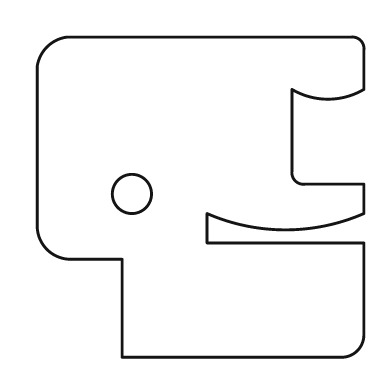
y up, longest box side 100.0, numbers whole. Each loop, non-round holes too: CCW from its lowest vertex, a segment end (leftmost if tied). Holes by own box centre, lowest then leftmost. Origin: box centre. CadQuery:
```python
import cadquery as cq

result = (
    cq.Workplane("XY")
    .moveTo(-24.0, -49.0)
    .lineTo(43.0, -49.0)
    .threePointArc((48.0, -47.0), (50.0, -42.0))
    .lineTo(50.0, -14.0)
    .lineTo(2.0, -14.0)
    .lineTo(2.0, -5.0)
    .threePointArc((26.0, -10.0), (50.0, -5.0))
    .lineTo(50.0, 4.0)
    .lineTo(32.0, 4.0)
    .threePointArc((29.0, 5.0), (28.0, 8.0))
    .lineTo(28.0, 33.0)
    .threePointArc((39.0, 30.0), (50.0, 33.0))
    .lineTo(50.0, 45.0)
    .threePointArc((49.0, 48.0), (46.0, 49.0))
    .lineTo(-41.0, 49.0)
    .threePointArc((-47.0, 46.0), (-50.0, 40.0))
    .lineTo(-50.0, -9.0)
    .threePointArc((-47.0, -16.0), (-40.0, -19.0))
    .lineTo(-24.0, -19.0)
    .close()
    .moveTo(-21.0, 1.0)
    .circle(6.0)
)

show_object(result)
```